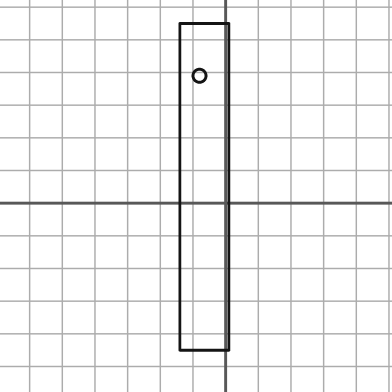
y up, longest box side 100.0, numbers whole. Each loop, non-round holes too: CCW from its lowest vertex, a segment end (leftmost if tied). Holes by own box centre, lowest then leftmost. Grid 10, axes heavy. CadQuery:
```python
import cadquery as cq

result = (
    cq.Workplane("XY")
    .moveTo(-14.0, -45.0)
    .lineTo(1.0, -45.0)
    .lineTo(1.0, 55.0)
    .lineTo(-14.0, 55.0)
    .close()
    .moveTo(-8.0, 39.0)
    .circle(2.0)
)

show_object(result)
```